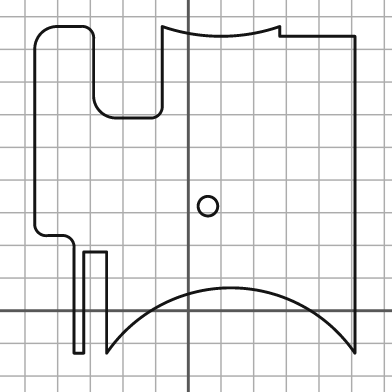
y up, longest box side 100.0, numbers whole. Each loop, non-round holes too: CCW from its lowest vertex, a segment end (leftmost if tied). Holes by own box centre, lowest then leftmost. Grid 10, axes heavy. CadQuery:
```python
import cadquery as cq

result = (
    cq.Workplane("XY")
    .moveTo(-35.0, -13.0)
    .lineTo(-32.0, -13.0)
    .lineTo(-32.0, 18.0)
    .lineTo(-25.0, 18.0)
    .lineTo(-25.0, -13.0)
    .threePointArc((13.0, 7.0), (51.0, -13.0))
    .lineTo(51.0, 84.0)
    .lineTo(28.0, 84.0)
    .lineTo(28.0, 87.0)
    .threePointArc((10.0, 84.0), (-8.0, 87.0))
    .lineTo(-8.0, 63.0)
    .threePointArc((-9.0, 60.0), (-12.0, 59.0))
    .lineTo(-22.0, 59.0)
    .threePointArc((-27.0, 61.0), (-29.0, 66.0))
    .lineTo(-29.0, 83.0)
    .threePointArc((-30.0, 86.0), (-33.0, 87.0))
    .lineTo(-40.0, 87.0)
    .threePointArc((-45.0, 85.0), (-47.0, 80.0))
    .lineTo(-47.0, 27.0)
    .threePointArc((-46.0, 24.0), (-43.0, 23.0))
    .lineTo(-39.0, 23.0)
    .threePointArc((-36.0, 22.0), (-35.0, 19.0))
    .close()
    .moveTo(6.0, 32.0)
    .circle(3.0)
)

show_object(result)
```